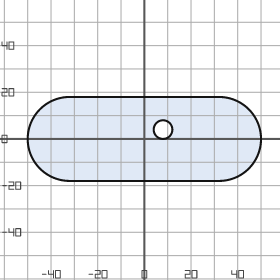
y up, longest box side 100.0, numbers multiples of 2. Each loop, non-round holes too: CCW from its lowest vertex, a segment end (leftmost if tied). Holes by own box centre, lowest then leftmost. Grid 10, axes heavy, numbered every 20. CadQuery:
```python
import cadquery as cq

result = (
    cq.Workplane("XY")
    .moveTo(-32.0, -18.0)
    .lineTo(32.0, -18.0)
    .threePointArc((50.0, 0.0), (32.0, 18.0))
    .lineTo(-32.0, 18.0)
    .threePointArc((-50.0, 0.0), (-32.0, -18.0))
    .close()
    .moveTo(8.0, 4.0)
    .circle(4.0)
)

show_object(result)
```